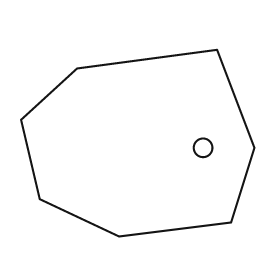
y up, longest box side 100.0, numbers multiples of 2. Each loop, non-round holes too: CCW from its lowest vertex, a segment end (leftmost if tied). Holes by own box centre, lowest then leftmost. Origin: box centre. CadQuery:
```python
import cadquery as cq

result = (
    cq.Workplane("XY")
    .moveTo(-8.0, -40.0)
    .lineTo(40.0, -34.0)
    .lineTo(50.0, -2.0)
    .lineTo(34.0, 40.0)
    .lineTo(-26.0, 32.0)
    .lineTo(-50.0, 10.0)
    .lineTo(-42.0, -24.0)
    .close()
    .moveTo(28.0, -2.0)
    .circle(4.0)
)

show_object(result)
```